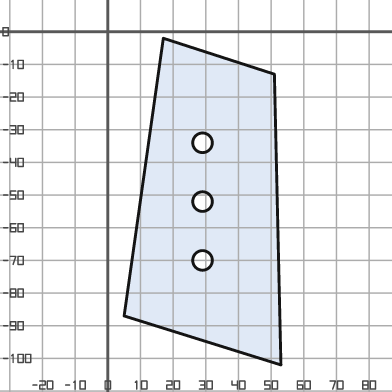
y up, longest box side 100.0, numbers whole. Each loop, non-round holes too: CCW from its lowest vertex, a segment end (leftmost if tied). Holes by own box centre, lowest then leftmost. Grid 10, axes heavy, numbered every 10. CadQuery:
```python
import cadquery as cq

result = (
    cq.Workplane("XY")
    .moveTo(53.0, -102.0)
    .lineTo(51.0, -13.0)
    .lineTo(17.0, -2.0)
    .lineTo(5.0, -87.0)
    .close()
    .moveTo(29.0, -70.0)
    .circle(3.0)
    .moveTo(29.0, -52.0)
    .circle(3.0)
    .moveTo(29.0, -34.0)
    .circle(3.0)
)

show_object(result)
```